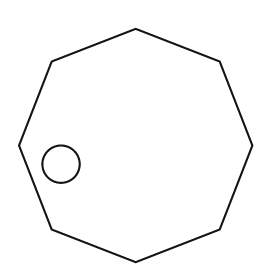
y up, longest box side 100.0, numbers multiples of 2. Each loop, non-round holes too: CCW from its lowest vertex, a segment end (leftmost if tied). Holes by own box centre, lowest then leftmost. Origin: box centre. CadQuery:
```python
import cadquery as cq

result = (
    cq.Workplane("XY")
    .moveTo(0.0, -50.0)
    .lineTo(36.0, -36.0)
    .lineTo(50.0, 0.0)
    .lineTo(36.0, 36.0)
    .lineTo(0.0, 50.0)
    .lineTo(-36.0, 36.0)
    .lineTo(-50.0, 0.0)
    .lineTo(-36.0, -36.0)
    .close()
    .moveTo(-32.0, -8.0)
    .circle(8.0)
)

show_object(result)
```